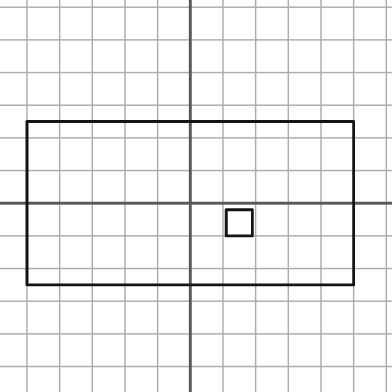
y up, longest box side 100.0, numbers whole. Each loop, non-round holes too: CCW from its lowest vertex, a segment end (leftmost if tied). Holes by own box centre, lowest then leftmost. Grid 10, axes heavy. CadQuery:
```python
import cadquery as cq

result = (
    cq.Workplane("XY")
    .moveTo(-50.0, -25.0)
    .lineTo(50.0, -25.0)
    .lineTo(50.0, 25.0)
    .lineTo(-50.0, 25.0)
    .close()
    .moveTo(11.0, -10.0)
    .lineTo(19.0, -10.0)
    .lineTo(19.0, -2.0)
    .lineTo(11.0, -2.0)
    .close()
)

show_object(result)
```